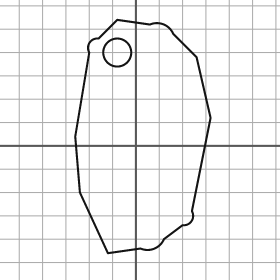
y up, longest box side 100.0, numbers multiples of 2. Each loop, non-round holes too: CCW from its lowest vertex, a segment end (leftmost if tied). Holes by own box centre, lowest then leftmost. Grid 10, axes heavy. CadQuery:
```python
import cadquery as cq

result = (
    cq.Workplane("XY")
    .moveTo(-12.0, -46.0)
    .lineTo(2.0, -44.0)
    .threePointArc((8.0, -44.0), (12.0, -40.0))
    .lineTo(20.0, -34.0)
    .threePointArc((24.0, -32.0), (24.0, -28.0))
    .lineTo(32.0, 12.0)
    .lineTo(26.0, 38.0)
    .lineTo(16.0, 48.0)
    .threePointArc((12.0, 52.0), (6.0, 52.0))
    .lineTo(-8.0, 54.0)
    .lineTo(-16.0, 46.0)
    .threePointArc((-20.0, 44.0), (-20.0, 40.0))
    .lineTo(-26.0, 4.0)
    .lineTo(-24.0, -20.0)
    .close()
    .moveTo(-8.0, 40.0)
    .circle(6.0)
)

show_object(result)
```